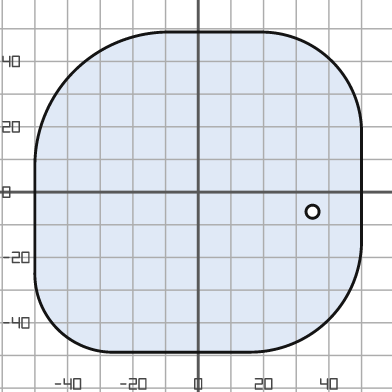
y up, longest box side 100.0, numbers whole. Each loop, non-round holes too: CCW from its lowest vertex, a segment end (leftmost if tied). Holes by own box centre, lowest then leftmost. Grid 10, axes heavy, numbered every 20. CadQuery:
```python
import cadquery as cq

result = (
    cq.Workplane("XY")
    .moveTo(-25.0, -49.0)
    .lineTo(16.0, -49.0)
    .threePointArc((40.0, -39.0), (50.0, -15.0))
    .lineTo(50.0, 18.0)
    .threePointArc((41.0, 40.0), (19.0, 49.0))
    .lineTo(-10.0, 49.0)
    .threePointArc((-38.0, 37.0), (-50.0, 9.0))
    .lineTo(-50.0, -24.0)
    .threePointArc((-43.0, -42.0), (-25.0, -49.0))
    .close()
    .moveTo(35.0, -6.0)
    .circle(2.0)
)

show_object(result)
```